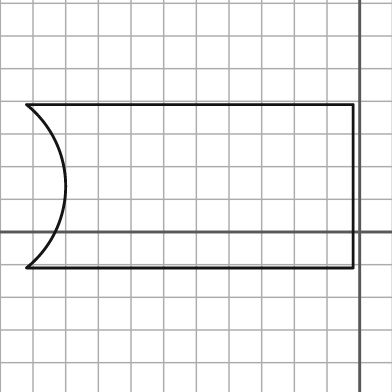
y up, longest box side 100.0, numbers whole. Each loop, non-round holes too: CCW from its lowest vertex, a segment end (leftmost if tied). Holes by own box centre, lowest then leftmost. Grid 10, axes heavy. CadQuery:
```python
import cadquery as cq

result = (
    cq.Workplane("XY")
    .moveTo(-102.0, -11.0)
    .lineTo(-2.0, -11.0)
    .lineTo(-2.0, 39.0)
    .lineTo(-102.0, 39.0)
    .threePointArc((-90.0, 14.0), (-102.0, -11.0))
    .close()
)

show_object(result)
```